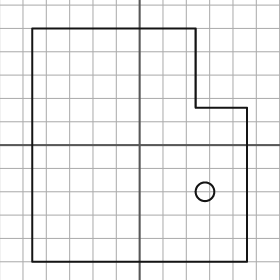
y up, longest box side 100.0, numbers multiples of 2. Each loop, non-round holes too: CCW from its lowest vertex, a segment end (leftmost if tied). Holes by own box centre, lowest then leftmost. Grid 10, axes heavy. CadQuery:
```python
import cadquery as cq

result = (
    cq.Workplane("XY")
    .moveTo(-46.0, -50.0)
    .lineTo(46.0, -50.0)
    .lineTo(46.0, 16.0)
    .lineTo(24.0, 16.0)
    .lineTo(24.0, 50.0)
    .lineTo(-46.0, 50.0)
    .close()
    .moveTo(28.0, -20.0)
    .circle(4.0)
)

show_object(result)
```